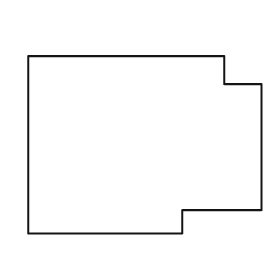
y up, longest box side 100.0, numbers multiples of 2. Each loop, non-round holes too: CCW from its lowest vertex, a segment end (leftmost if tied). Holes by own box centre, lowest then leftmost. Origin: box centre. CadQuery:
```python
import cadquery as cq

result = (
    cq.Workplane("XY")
    .moveTo(-50.0, -38.0)
    .lineTo(16.0, -38.0)
    .lineTo(16.0, -28.0)
    .lineTo(50.0, -28.0)
    .lineTo(50.0, 26.0)
    .lineTo(34.0, 26.0)
    .lineTo(34.0, 38.0)
    .lineTo(-50.0, 38.0)
    .close()
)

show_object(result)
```